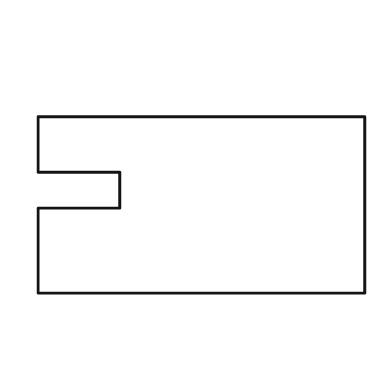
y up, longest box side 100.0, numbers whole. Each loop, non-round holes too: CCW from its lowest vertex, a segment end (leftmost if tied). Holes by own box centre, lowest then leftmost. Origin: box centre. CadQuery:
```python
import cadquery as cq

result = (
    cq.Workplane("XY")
    .moveTo(-50.0, -27.0)
    .lineTo(50.0, -27.0)
    .lineTo(50.0, 27.0)
    .lineTo(-50.0, 27.0)
    .lineTo(-50.0, 10.0)
    .lineTo(-25.0, 10.0)
    .lineTo(-25.0, -1.0)
    .lineTo(-50.0, -1.0)
    .close()
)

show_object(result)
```